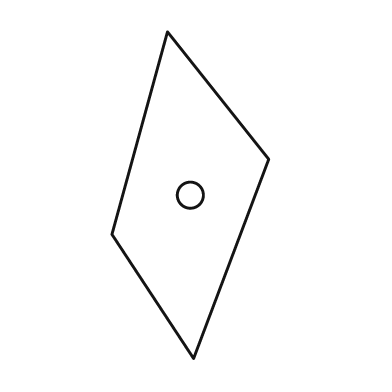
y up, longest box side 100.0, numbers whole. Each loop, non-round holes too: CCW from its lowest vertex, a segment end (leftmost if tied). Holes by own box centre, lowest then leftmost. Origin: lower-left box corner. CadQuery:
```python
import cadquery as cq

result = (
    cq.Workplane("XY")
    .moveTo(25.0, 0.0)
    .lineTo(48.0, 61.0)
    .lineTo(17.0, 100.0)
    .lineTo(0.0, 38.0)
    .close()
    .moveTo(24.0, 50.0)
    .circle(4.0)
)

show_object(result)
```